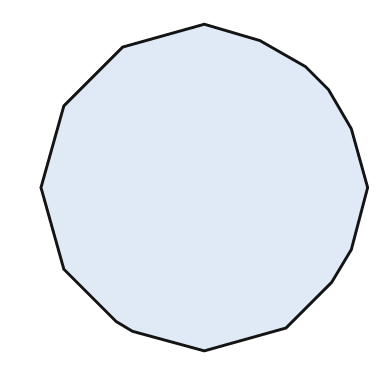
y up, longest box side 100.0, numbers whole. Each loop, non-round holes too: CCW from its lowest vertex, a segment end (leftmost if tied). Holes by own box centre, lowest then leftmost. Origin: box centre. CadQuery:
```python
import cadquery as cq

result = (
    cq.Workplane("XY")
    .moveTo(0.0, -50.0)
    .lineTo(25.0, -43.0)
    .lineTo(39.0, -29.0)
    .lineTo(45.0, -19.0)
    .lineTo(50.0, 0.0)
    .lineTo(45.0, 18.0)
    .lineTo(38.0, 30.0)
    .lineTo(31.0, 37.0)
    .lineTo(17.0, 45.0)
    .lineTo(0.0, 50.0)
    .lineTo(-25.0, 43.0)
    .lineTo(-43.0, 25.0)
    .lineTo(-50.0, 0.0)
    .lineTo(-43.0, -25.0)
    .lineTo(-27.0, -41.0)
    .lineTo(-22.0, -44.0)
    .close()
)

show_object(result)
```